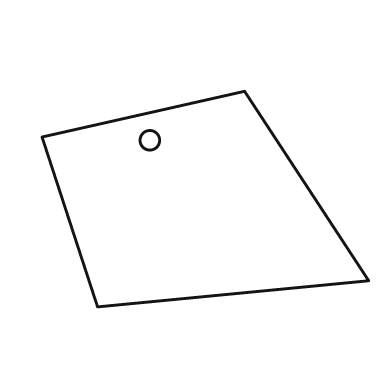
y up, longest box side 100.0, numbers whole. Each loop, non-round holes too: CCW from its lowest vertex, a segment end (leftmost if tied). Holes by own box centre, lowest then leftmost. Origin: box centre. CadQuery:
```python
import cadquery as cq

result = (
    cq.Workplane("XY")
    .moveTo(-33.0, -33.0)
    .lineTo(50.0, -25.0)
    .lineTo(12.0, 33.0)
    .lineTo(-50.0, 19.0)
    .close()
    .moveTo(-17.0, 18.0)
    .circle(3.0)
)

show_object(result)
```